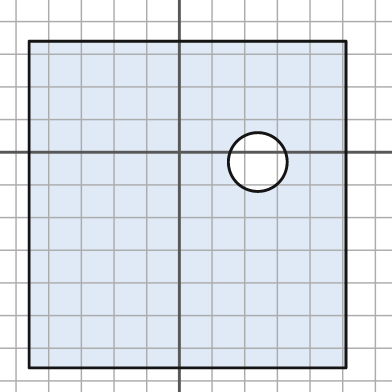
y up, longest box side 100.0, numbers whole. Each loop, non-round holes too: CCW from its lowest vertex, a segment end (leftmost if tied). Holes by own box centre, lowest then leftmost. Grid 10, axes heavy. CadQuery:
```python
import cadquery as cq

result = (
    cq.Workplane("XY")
    .moveTo(-46.0, -66.0)
    .lineTo(51.0, -66.0)
    .lineTo(51.0, 34.0)
    .lineTo(-46.0, 34.0)
    .close()
    .moveTo(24.0, -3.0)
    .circle(9.0)
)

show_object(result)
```